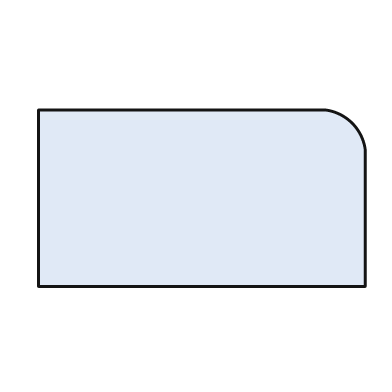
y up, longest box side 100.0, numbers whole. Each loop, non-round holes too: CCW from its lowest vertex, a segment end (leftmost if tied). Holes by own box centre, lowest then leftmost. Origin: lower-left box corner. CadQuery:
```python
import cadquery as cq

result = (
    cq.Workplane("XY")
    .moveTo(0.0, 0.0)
    .lineTo(100.0, 0.0)
    .lineTo(100.0, 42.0)
    .threePointArc((96.0, 50.0), (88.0, 54.0))
    .lineTo(0.0, 54.0)
    .close()
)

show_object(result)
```